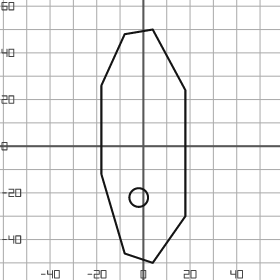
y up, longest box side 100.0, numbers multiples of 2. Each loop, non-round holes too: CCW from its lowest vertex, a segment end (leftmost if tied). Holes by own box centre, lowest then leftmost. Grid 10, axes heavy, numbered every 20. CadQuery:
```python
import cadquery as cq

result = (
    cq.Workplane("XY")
    .moveTo(4.0, -50.0)
    .lineTo(18.0, -30.0)
    .lineTo(18.0, 24.0)
    .lineTo(4.0, 50.0)
    .lineTo(-8.0, 48.0)
    .lineTo(-18.0, 26.0)
    .lineTo(-18.0, -12.0)
    .lineTo(-8.0, -46.0)
    .close()
    .moveTo(-2.0, -22.0)
    .circle(4.0)
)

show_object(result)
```